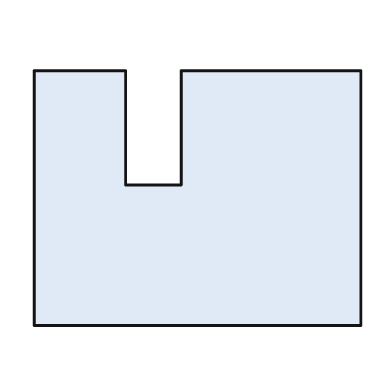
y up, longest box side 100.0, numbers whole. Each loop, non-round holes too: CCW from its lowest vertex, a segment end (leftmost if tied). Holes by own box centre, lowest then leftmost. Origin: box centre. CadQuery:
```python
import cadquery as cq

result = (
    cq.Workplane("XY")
    .moveTo(-50.0, -39.0)
    .lineTo(50.0, -39.0)
    .lineTo(50.0, 39.0)
    .lineTo(-5.0, 39.0)
    .lineTo(-5.0, 4.0)
    .lineTo(-22.0, 4.0)
    .lineTo(-22.0, 39.0)
    .lineTo(-50.0, 39.0)
    .close()
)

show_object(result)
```